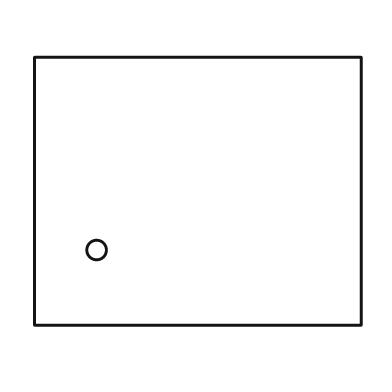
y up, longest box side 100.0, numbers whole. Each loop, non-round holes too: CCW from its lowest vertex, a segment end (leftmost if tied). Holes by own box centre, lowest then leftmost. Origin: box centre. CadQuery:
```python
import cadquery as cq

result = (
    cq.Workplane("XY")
    .moveTo(-50.0, -41.0)
    .lineTo(50.0, -41.0)
    .lineTo(50.0, 41.0)
    .lineTo(-50.0, 41.0)
    .close()
    .moveTo(-31.0, -18.0)
    .circle(3.0)
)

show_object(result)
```